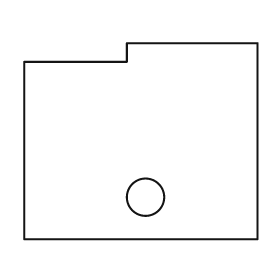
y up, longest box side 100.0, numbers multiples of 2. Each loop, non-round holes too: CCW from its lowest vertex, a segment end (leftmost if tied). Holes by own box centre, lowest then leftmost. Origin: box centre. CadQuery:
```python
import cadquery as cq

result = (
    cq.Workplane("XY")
    .moveTo(-50.0, -42.0)
    .lineTo(50.0, -42.0)
    .lineTo(50.0, 42.0)
    .lineTo(-6.0, 42.0)
    .lineTo(-6.0, 34.0)
    .lineTo(-50.0, 34.0)
    .close()
    .moveTo(2.0, -24.0)
    .circle(8.0)
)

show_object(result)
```